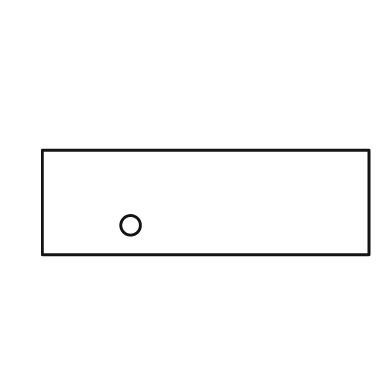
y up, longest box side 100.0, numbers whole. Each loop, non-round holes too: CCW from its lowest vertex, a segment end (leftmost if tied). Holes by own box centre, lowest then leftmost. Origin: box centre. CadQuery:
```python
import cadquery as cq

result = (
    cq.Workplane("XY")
    .moveTo(-50.0, -16.0)
    .lineTo(50.0, -16.0)
    .lineTo(50.0, 16.0)
    .lineTo(-50.0, 16.0)
    .close()
    .moveTo(-23.0, -7.0)
    .circle(3.0)
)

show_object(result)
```